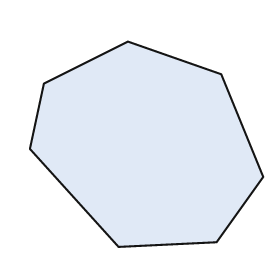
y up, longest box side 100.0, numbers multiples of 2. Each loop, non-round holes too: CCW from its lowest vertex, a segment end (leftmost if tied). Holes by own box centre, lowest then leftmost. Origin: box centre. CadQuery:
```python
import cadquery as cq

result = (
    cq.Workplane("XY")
    .moveTo(-12.0, -44.0)
    .lineTo(30.0, -42.0)
    .lineTo(50.0, -14.0)
    .lineTo(32.0, 30.0)
    .lineTo(-8.0, 44.0)
    .lineTo(-44.0, 26.0)
    .lineTo(-50.0, -2.0)
    .close()
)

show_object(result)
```